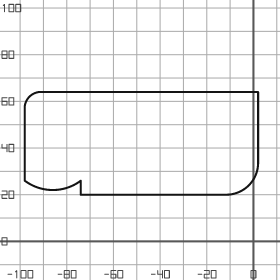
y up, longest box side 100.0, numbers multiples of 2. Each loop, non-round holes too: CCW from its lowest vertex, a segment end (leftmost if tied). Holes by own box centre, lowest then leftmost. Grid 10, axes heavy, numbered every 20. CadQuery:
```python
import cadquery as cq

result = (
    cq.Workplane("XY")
    .moveTo(-74.0, 20.0)
    .lineTo(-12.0, 20.0)
    .threePointArc((-2.0, 24.0), (2.0, 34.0))
    .lineTo(2.0, 64.0)
    .lineTo(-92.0, 64.0)
    .threePointArc((-96.0, 62.0), (-98.0, 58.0))
    .lineTo(-98.0, 26.0)
    .threePointArc((-86.0, 22.0), (-74.0, 26.0))
    .close()
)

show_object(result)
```